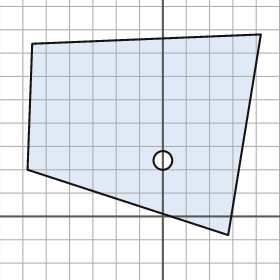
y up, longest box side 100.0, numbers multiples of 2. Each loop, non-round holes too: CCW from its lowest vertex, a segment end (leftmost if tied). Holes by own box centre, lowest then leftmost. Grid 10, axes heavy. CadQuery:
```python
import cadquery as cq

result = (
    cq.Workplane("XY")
    .moveTo(28.0, -8.0)
    .lineTo(42.0, 78.0)
    .lineTo(-56.0, 74.0)
    .lineTo(-58.0, 20.0)
    .close()
    .moveTo(0.0, 24.0)
    .circle(4.0)
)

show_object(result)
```